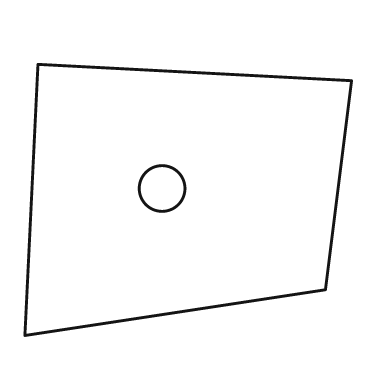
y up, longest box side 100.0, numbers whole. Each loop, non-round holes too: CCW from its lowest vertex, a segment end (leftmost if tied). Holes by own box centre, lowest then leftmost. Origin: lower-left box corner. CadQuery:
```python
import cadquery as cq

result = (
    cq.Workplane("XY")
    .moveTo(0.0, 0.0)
    .lineTo(92.0, 14.0)
    .lineTo(100.0, 78.0)
    .lineTo(4.0, 83.0)
    .close()
    .moveTo(42.0, 45.0)
    .circle(7.0)
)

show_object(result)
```